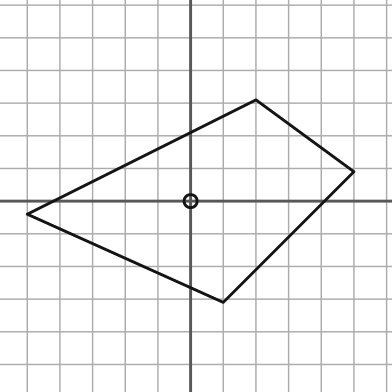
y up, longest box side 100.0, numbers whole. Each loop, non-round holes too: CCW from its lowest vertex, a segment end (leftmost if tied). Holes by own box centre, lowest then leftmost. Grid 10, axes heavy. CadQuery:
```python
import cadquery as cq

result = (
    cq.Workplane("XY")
    .moveTo(10.0, -31.0)
    .lineTo(50.0, 9.0)
    .lineTo(20.0, 31.0)
    .lineTo(-50.0, -4.0)
    .close()
    .moveTo(0.0, 0.0)
    .circle(2.0)
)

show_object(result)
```